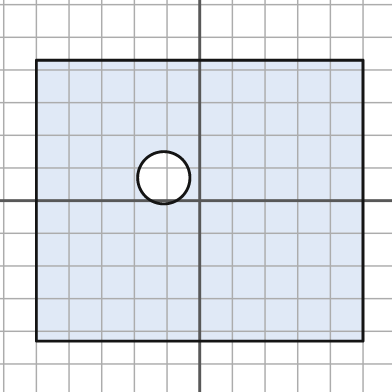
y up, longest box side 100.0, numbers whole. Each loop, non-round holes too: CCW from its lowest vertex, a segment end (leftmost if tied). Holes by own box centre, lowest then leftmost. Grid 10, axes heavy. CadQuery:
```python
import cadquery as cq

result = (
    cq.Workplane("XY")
    .moveTo(-50.0, -43.0)
    .lineTo(50.0, -43.0)
    .lineTo(50.0, 43.0)
    .lineTo(-50.0, 43.0)
    .close()
    .moveTo(-11.0, 7.0)
    .circle(8.0)
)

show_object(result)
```